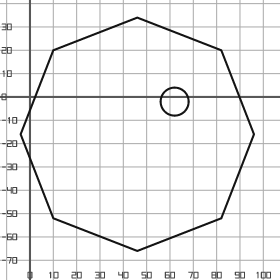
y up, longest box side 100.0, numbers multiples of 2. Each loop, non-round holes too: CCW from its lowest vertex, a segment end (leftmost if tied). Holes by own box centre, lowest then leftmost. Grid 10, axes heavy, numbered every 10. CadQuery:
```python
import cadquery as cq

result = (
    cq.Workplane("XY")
    .moveTo(46.0, -66.0)
    .lineTo(82.0, -52.0)
    .lineTo(96.0, -16.0)
    .lineTo(82.0, 20.0)
    .lineTo(46.0, 34.0)
    .lineTo(10.0, 20.0)
    .lineTo(-4.0, -16.0)
    .lineTo(10.0, -52.0)
    .close()
    .moveTo(62.0, -2.0)
    .circle(6.0)
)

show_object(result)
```